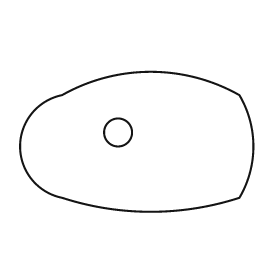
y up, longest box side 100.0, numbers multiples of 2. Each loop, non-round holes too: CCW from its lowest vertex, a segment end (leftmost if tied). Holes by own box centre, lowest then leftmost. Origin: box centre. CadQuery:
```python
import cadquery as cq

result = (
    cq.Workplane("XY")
    .moveTo(-32.0, -24.0)
    .threePointArc((6.0, -30.0), (44.0, -24.0))
    .threePointArc((50.0, -2.0), (44.0, 20.0))
    .threePointArc((6.0, 30.0), (-32.0, 20.0))
    .threePointArc((-50.0, -2.0), (-32.0, -24.0))
    .close()
    .moveTo(-8.0, 4.0)
    .circle(6.0)
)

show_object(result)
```